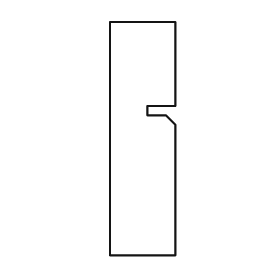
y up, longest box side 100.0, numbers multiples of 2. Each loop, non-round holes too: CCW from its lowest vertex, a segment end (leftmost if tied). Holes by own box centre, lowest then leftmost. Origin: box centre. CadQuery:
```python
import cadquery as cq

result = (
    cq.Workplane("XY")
    .moveTo(-14.0, -50.0)
    .lineTo(14.0, -50.0)
    .lineTo(14.0, 6.0)
    .lineTo(10.0, 10.0)
    .lineTo(2.0, 10.0)
    .lineTo(2.0, 14.0)
    .lineTo(14.0, 14.0)
    .lineTo(14.0, 50.0)
    .lineTo(-14.0, 50.0)
    .close()
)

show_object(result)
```